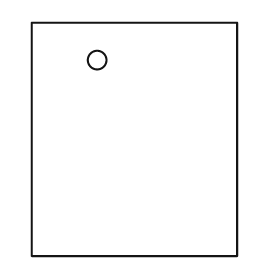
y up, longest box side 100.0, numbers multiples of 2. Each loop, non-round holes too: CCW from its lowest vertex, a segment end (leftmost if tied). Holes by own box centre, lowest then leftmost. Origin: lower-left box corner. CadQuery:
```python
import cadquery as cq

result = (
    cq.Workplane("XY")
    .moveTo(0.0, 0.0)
    .lineTo(88.0, 0.0)
    .lineTo(88.0, 100.0)
    .lineTo(0.0, 100.0)
    .close()
    .moveTo(28.0, 84.0)
    .circle(4.0)
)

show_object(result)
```